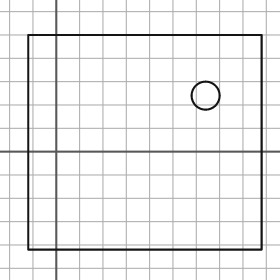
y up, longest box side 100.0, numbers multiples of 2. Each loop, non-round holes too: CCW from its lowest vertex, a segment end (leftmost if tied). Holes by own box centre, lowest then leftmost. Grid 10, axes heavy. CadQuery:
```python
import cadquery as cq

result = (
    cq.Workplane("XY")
    .moveTo(-12.0, -42.0)
    .lineTo(88.0, -42.0)
    .lineTo(88.0, 50.0)
    .lineTo(-12.0, 50.0)
    .close()
    .moveTo(64.0, 24.0)
    .circle(6.0)
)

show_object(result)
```